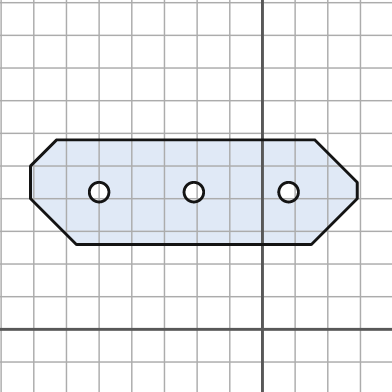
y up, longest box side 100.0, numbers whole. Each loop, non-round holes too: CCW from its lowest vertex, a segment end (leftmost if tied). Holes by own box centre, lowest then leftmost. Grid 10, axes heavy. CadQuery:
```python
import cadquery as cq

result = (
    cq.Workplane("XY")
    .moveTo(-57.0, 26.0)
    .lineTo(15.0, 26.0)
    .lineTo(29.0, 40.0)
    .lineTo(29.0, 45.0)
    .lineTo(16.0, 58.0)
    .lineTo(-63.0, 58.0)
    .lineTo(-71.0, 50.0)
    .lineTo(-71.0, 40.0)
    .close()
    .moveTo(-50.0, 42.0)
    .circle(3.0)
    .moveTo(-21.0, 42.0)
    .circle(3.0)
    .moveTo(8.0, 42.0)
    .circle(3.0)
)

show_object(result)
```